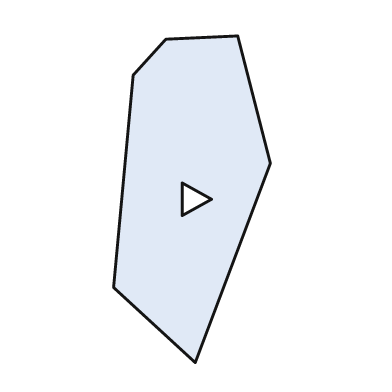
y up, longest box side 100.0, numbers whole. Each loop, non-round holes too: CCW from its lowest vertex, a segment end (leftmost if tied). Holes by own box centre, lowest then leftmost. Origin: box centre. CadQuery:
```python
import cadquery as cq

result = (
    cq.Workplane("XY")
    .moveTo(1.0, -50.0)
    .lineTo(24.0, 11.0)
    .lineTo(14.0, 50.0)
    .lineTo(-8.0, 49.0)
    .lineTo(-18.0, 38.0)
    .lineTo(-24.0, -27.0)
    .close()
    .moveTo(-3.0, -5.0)
    .lineTo(6.0, 0.0)
    .lineTo(-3.0, 5.0)
    .close()
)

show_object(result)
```